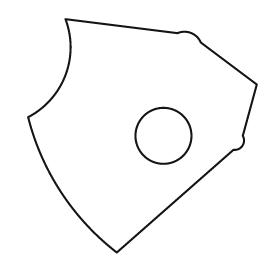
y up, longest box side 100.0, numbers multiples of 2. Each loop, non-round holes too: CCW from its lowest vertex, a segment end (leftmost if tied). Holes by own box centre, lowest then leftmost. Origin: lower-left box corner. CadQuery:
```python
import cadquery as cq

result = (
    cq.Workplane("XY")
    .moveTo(38.0, 0.0)
    .lineTo(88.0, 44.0)
    .threePointArc((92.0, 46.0), (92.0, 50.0))
    .lineTo(98.0, 72.0)
    .lineTo(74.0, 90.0)
    .threePointArc((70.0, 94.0), (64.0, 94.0))
    .lineTo(16.0, 100.0)
    .threePointArc((16.0, 76.0), (0.0, 58.0))
    .threePointArc((14.0, 26.0), (38.0, 0.0))
    .close()
    .moveTo(58.0, 50.0)
    .circle(12.0)
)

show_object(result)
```